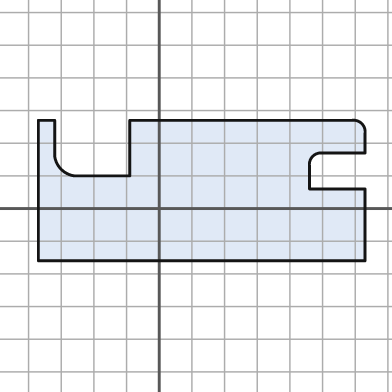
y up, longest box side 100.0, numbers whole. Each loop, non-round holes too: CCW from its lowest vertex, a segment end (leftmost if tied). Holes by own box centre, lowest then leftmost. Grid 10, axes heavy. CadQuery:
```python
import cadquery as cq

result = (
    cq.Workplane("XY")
    .moveTo(-37.0, -16.0)
    .lineTo(63.0, -16.0)
    .lineTo(63.0, 6.0)
    .lineTo(46.0, 6.0)
    .lineTo(46.0, 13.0)
    .threePointArc((47.0, 16.0), (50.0, 17.0))
    .lineTo(63.0, 17.0)
    .lineTo(63.0, 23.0)
    .threePointArc((62.0, 26.0), (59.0, 27.0))
    .lineTo(-9.0, 27.0)
    .lineTo(-9.0, 10.0)
    .lineTo(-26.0, 10.0)
    .threePointArc((-30.0, 12.0), (-32.0, 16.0))
    .lineTo(-32.0, 27.0)
    .lineTo(-37.0, 27.0)
    .close()
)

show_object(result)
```